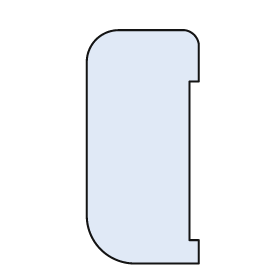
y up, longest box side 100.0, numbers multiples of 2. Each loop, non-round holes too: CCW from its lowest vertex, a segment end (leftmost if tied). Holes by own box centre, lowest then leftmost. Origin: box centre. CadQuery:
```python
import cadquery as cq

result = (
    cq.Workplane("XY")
    .moveTo(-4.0, -50.0)
    .lineTo(24.0, -50.0)
    .lineTo(24.0, -40.0)
    .lineTo(20.0, -40.0)
    .lineTo(20.0, 28.0)
    .lineTo(24.0, 28.0)
    .lineTo(24.0, 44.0)
    .threePointArc((22.0, 48.0), (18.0, 50.0))
    .lineTo(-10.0, 50.0)
    .threePointArc((-20.0, 46.0), (-24.0, 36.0))
    .lineTo(-24.0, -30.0)
    .threePointArc((-18.0, -44.0), (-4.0, -50.0))
    .close()
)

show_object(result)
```